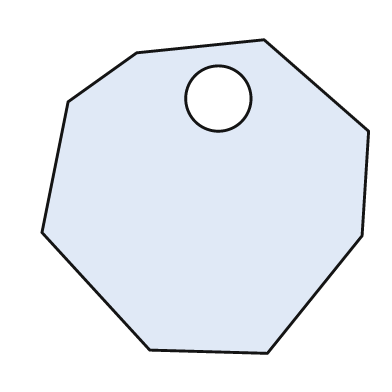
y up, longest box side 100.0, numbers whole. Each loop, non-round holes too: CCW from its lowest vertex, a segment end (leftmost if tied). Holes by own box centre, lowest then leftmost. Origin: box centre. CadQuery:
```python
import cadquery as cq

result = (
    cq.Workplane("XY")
    .moveTo(19.0, -48.0)
    .lineTo(48.0, -12.0)
    .lineTo(50.0, 20.0)
    .lineTo(18.0, 48.0)
    .lineTo(-21.0, 44.0)
    .lineTo(-42.0, 29.0)
    .lineTo(-50.0, -11.0)
    .lineTo(-17.0, -47.0)
    .close()
    .moveTo(4.0, 30.0)
    .circle(10.0)
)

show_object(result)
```